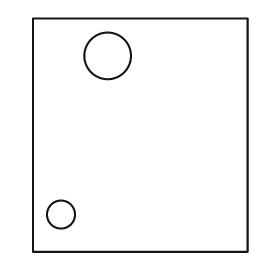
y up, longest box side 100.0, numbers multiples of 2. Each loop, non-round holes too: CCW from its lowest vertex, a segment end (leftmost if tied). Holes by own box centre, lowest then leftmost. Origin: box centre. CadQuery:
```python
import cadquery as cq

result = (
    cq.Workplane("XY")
    .moveTo(-46.0, -50.0)
    .lineTo(46.0, -50.0)
    .lineTo(46.0, 50.0)
    .lineTo(-46.0, 50.0)
    .close()
    .moveTo(-34.0, -34.0)
    .circle(6.0)
    .moveTo(-14.0, 34.0)
    .circle(10.0)
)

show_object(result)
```